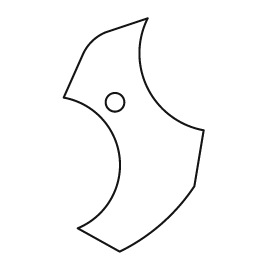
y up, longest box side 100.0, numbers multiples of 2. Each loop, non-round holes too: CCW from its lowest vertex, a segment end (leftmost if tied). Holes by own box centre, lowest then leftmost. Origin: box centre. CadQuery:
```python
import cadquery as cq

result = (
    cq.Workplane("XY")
    .moveTo(-6.0, -50.0)
    .threePointArc((12.0, -38.0), (26.0, -22.0))
    .lineTo(30.0, 2.0)
    .threePointArc((6.0, 20.0), (6.0, 50.0))
    .lineTo(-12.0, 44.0)
    .threePointArc((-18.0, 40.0), (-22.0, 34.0))
    .lineTo(-30.0, 16.0)
    .threePointArc((-6.0, -10.0), (-24.0, -40.0))
    .close()
    .moveTo(-8.0, 14.0)
    .circle(4.0)
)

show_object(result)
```